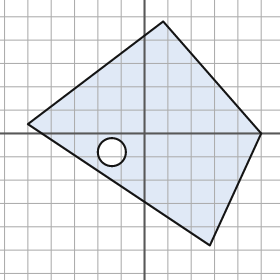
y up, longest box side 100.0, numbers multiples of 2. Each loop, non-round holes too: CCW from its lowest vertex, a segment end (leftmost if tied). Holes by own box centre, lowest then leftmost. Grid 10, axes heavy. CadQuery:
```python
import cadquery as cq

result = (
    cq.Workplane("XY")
    .moveTo(28.0, -48.0)
    .lineTo(50.0, 0.0)
    .lineTo(8.0, 48.0)
    .lineTo(-50.0, 4.0)
    .close()
    .moveTo(-14.0, -8.0)
    .circle(6.0)
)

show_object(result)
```